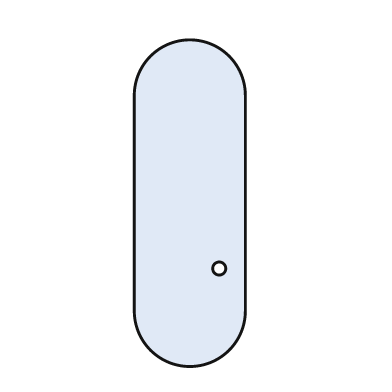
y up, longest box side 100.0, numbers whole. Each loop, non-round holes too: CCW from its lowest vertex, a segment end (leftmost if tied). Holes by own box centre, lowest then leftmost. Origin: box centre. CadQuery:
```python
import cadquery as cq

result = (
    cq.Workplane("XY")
    .moveTo(-17.0, -33.0)
    .threePointArc((0.0, -50.0), (17.0, -33.0))
    .lineTo(17.0, 33.0)
    .threePointArc((0.0, 50.0), (-17.0, 33.0))
    .close()
    .moveTo(9.0, -20.0)
    .circle(2.0)
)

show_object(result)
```